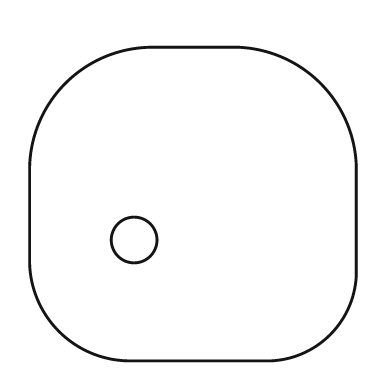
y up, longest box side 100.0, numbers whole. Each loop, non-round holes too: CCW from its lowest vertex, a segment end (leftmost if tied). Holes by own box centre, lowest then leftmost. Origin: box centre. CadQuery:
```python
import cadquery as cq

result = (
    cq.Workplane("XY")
    .moveTo(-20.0, -48.0)
    .lineTo(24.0, -48.0)
    .threePointArc((42.0, -40.0), (50.0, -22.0))
    .lineTo(50.0, 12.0)
    .threePointArc((39.0, 37.0), (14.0, 48.0))
    .lineTo(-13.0, 48.0)
    .threePointArc((-39.0, 37.0), (-50.0, 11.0))
    .lineTo(-50.0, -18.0)
    .threePointArc((-41.0, -39.0), (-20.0, -48.0))
    .close()
    .moveTo(-18.0, -11.0)
    .circle(7.0)
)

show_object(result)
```